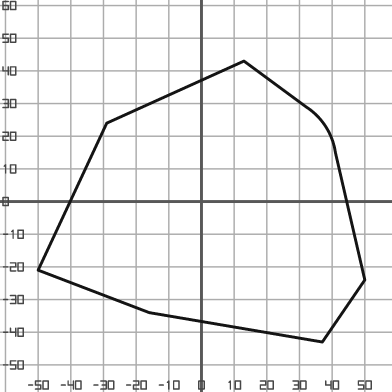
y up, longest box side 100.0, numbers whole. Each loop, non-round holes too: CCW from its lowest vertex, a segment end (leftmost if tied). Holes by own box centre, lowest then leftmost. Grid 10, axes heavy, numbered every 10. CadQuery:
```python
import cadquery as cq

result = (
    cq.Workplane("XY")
    .moveTo(37.0, -43.0)
    .lineTo(50.0, -24.0)
    .lineTo(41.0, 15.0)
    .threePointArc((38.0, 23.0), (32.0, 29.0))
    .lineTo(13.0, 43.0)
    .lineTo(-29.0, 24.0)
    .lineTo(-50.0, -21.0)
    .lineTo(-16.0, -34.0)
    .close()
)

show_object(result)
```